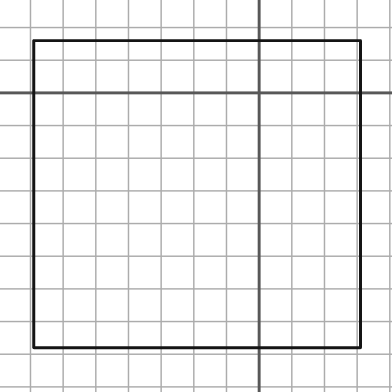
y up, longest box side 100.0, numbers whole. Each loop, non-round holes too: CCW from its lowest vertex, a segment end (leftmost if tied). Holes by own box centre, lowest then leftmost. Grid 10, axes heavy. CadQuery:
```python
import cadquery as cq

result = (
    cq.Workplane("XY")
    .moveTo(-69.0, -78.0)
    .lineTo(31.0, -78.0)
    .lineTo(31.0, 16.0)
    .lineTo(-69.0, 16.0)
    .close()
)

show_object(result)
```